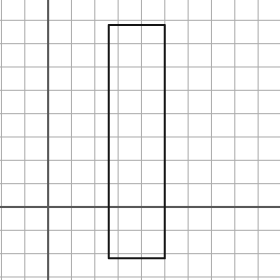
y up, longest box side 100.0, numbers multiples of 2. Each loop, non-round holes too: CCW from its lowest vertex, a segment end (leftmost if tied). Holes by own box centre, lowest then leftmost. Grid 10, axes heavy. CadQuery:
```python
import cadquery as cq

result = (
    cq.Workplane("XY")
    .moveTo(26.0, -22.0)
    .lineTo(50.0, -22.0)
    .lineTo(50.0, 78.0)
    .lineTo(26.0, 78.0)
    .close()
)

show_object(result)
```